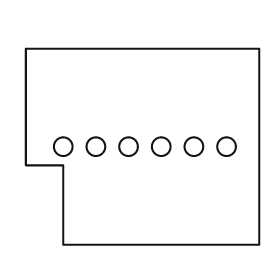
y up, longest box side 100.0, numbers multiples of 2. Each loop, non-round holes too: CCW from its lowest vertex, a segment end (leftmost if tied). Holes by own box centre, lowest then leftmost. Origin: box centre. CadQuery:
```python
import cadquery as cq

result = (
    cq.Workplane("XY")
    .moveTo(-34.0, -42.0)
    .lineTo(50.0, -42.0)
    .lineTo(50.0, 42.0)
    .lineTo(-50.0, 42.0)
    .lineTo(-50.0, -8.0)
    .lineTo(-34.0, -8.0)
    .close()
    .moveTo(-34.0, 0.0)
    .circle(4.0)
    .moveTo(-20.0, 0.0)
    .circle(4.0)
    .moveTo(-6.0, 0.0)
    .circle(4.0)
    .moveTo(8.0, 0.0)
    .circle(4.0)
    .moveTo(22.0, 0.0)
    .circle(4.0)
    .moveTo(36.0, 0.0)
    .circle(4.0)
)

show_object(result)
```